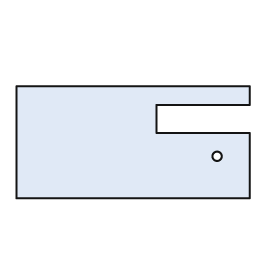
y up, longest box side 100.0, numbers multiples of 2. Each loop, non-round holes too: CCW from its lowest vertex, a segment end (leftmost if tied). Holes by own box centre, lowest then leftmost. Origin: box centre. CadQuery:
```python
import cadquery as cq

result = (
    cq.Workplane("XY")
    .moveTo(-50.0, -24.0)
    .lineTo(50.0, -24.0)
    .lineTo(50.0, 4.0)
    .lineTo(10.0, 4.0)
    .lineTo(10.0, 16.0)
    .lineTo(50.0, 16.0)
    .lineTo(50.0, 24.0)
    .lineTo(-50.0, 24.0)
    .close()
    .moveTo(36.0, -6.0)
    .circle(2.0)
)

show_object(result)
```